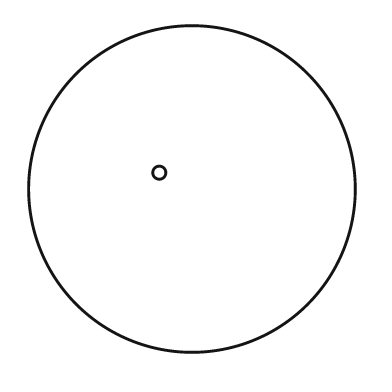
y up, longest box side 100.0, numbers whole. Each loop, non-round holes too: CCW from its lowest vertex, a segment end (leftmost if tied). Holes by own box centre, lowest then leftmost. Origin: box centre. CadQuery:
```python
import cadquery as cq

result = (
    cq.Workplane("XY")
    .moveTo(0.0, 0.0)
    .circle(50.0)
    .moveTo(-10.0, 5.0)
    .circle(2.0)
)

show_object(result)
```